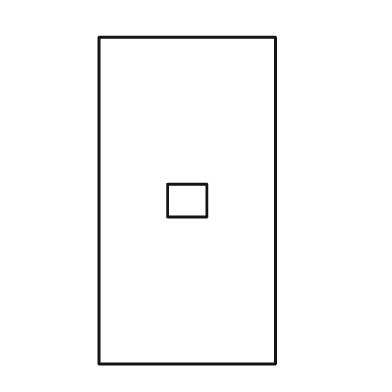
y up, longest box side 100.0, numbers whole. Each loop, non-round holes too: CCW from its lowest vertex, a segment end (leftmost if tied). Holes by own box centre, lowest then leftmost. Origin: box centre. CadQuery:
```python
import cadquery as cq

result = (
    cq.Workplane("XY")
    .moveTo(-27.0, -50.0)
    .lineTo(27.0, -50.0)
    .lineTo(27.0, 50.0)
    .lineTo(-27.0, 50.0)
    .close()
    .moveTo(-6.0, -5.0)
    .lineTo(6.0, -5.0)
    .lineTo(6.0, 5.0)
    .lineTo(-6.0, 5.0)
    .close()
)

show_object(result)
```